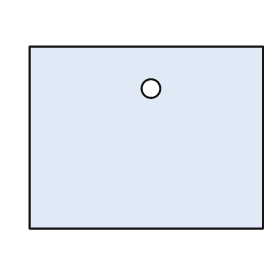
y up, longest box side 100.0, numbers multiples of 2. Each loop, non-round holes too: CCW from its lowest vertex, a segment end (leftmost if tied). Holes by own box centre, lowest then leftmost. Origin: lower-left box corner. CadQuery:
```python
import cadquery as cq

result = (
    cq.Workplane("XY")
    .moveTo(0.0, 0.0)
    .lineTo(100.0, 0.0)
    .lineTo(100.0, 78.0)
    .lineTo(0.0, 78.0)
    .close()
    .moveTo(52.0, 60.0)
    .circle(4.0)
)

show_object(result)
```